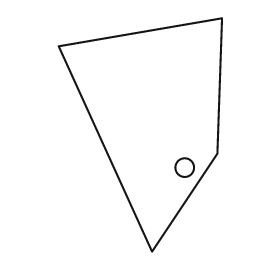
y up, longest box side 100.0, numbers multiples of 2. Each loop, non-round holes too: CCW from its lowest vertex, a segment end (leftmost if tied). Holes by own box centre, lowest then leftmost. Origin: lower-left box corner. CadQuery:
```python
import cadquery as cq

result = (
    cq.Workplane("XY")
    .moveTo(40.0, 0.0)
    .lineTo(68.0, 42.0)
    .lineTo(70.0, 100.0)
    .lineTo(0.0, 88.0)
    .close()
    .moveTo(54.0, 36.0)
    .circle(4.0)
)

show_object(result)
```